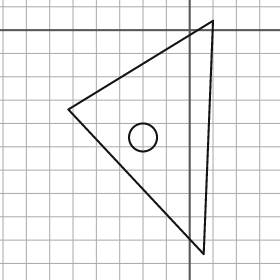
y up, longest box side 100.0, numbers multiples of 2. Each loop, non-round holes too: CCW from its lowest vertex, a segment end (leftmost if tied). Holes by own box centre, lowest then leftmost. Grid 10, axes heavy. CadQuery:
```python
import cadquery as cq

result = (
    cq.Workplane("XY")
    .moveTo(6.0, -96.0)
    .lineTo(10.0, 4.0)
    .lineTo(-52.0, -34.0)
    .close()
    .moveTo(-20.0, -46.0)
    .circle(6.0)
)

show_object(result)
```